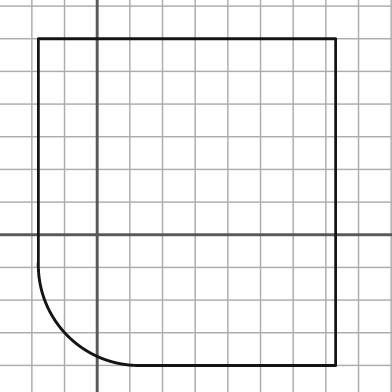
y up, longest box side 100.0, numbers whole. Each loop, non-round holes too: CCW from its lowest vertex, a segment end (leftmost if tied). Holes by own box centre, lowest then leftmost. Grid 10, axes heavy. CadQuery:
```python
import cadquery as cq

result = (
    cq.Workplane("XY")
    .moveTo(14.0, -40.0)
    .lineTo(73.0, -40.0)
    .lineTo(73.0, 60.0)
    .lineTo(-18.0, 60.0)
    .lineTo(-18.0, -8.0)
    .threePointArc((-9.0, -31.0), (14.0, -40.0))
    .close()
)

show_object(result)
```